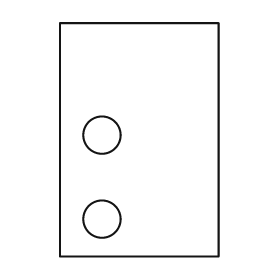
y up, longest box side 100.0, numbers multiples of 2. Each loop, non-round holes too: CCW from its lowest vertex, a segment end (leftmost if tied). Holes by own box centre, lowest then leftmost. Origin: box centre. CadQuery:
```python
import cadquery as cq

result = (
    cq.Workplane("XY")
    .moveTo(-34.0, -50.0)
    .lineTo(34.0, -50.0)
    .lineTo(34.0, 50.0)
    .lineTo(-34.0, 50.0)
    .close()
    .moveTo(-16.0, -34.0)
    .circle(8.0)
    .moveTo(-16.0, 2.0)
    .circle(8.0)
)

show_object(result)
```